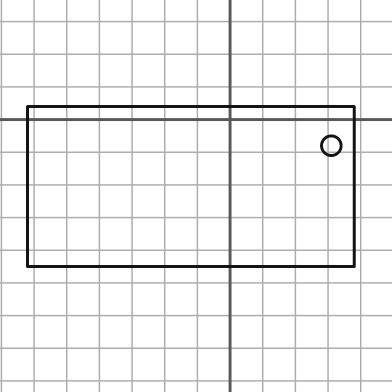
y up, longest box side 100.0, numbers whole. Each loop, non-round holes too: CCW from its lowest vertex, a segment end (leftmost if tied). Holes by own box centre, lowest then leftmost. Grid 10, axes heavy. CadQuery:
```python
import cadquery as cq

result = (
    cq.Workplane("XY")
    .moveTo(-62.0, -45.0)
    .lineTo(38.0, -45.0)
    .lineTo(38.0, 4.0)
    .lineTo(-62.0, 4.0)
    .close()
    .moveTo(31.0, -8.0)
    .circle(3.0)
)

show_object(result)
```